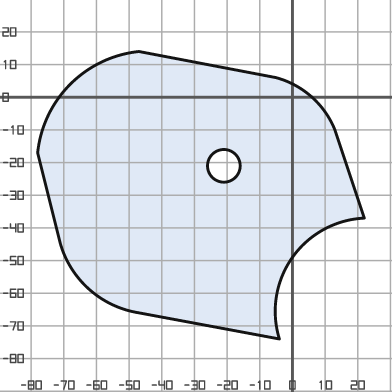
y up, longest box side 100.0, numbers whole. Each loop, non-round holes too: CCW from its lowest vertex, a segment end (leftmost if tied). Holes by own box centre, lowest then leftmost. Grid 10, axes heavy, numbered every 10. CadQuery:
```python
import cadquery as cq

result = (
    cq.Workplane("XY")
    .moveTo(-4.0, -74.0)
    .threePointArc((0.0, -49.0), (22.0, -37.0))
    .lineTo(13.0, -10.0)
    .threePointArc((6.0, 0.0), (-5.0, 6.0))
    .lineTo(-47.0, 14.0)
    .threePointArc((-68.0, 4.0), (-78.0, -17.0))
    .lineTo(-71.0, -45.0)
    .threePointArc((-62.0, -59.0), (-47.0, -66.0))
    .close()
    .moveTo(-21.0, -21.0)
    .circle(5.0)
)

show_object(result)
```